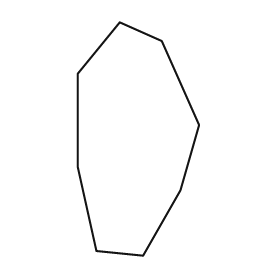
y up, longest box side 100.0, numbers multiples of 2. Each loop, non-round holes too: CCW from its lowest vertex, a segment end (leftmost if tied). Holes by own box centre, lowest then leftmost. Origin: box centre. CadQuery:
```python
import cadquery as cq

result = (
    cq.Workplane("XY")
    .moveTo(2.0, -50.0)
    .lineTo(18.0, -22.0)
    .lineTo(26.0, 6.0)
    .lineTo(10.0, 42.0)
    .lineTo(-8.0, 50.0)
    .lineTo(-26.0, 28.0)
    .lineTo(-26.0, -12.0)
    .lineTo(-18.0, -48.0)
    .close()
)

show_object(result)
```